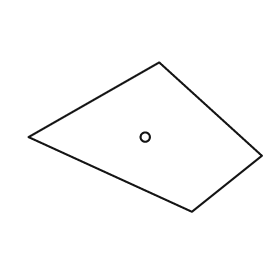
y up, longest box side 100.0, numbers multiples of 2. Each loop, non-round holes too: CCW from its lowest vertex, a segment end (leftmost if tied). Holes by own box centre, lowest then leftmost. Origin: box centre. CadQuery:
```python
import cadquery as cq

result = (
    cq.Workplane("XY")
    .moveTo(20.0, -32.0)
    .lineTo(50.0, -8.0)
    .lineTo(6.0, 32.0)
    .lineTo(-50.0, 0.0)
    .close()
    .moveTo(0.0, 0.0)
    .circle(2.0)
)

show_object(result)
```